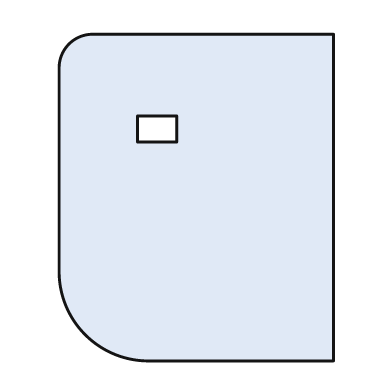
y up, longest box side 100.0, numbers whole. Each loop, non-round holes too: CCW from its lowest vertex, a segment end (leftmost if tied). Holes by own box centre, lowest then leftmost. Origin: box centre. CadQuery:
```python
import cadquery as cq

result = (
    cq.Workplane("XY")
    .moveTo(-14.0, -50.0)
    .lineTo(42.0, -50.0)
    .lineTo(42.0, 50.0)
    .lineTo(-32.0, 50.0)
    .threePointArc((-39.0, 47.0), (-42.0, 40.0))
    .lineTo(-42.0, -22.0)
    .threePointArc((-34.0, -42.0), (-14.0, -50.0))
    .close()
    .moveTo(-18.0, 17.0)
    .lineTo(-6.0, 17.0)
    .lineTo(-6.0, 25.0)
    .lineTo(-18.0, 25.0)
    .close()
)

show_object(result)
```